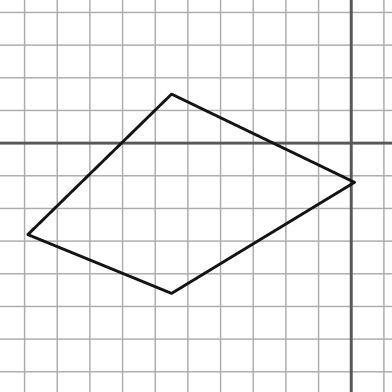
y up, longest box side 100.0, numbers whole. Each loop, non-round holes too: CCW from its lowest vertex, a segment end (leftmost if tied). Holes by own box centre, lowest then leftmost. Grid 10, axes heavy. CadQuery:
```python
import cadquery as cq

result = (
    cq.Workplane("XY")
    .moveTo(-55.0, -46.0)
    .lineTo(1.0, -12.0)
    .lineTo(-55.0, 15.0)
    .lineTo(-99.0, -28.0)
    .close()
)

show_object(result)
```